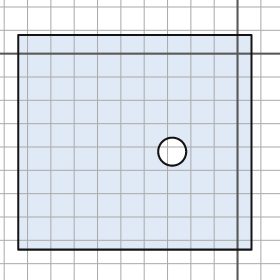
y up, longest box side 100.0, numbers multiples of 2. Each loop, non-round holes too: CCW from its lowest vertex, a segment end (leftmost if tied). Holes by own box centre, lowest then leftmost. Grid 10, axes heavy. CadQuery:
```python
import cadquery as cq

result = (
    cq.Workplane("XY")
    .moveTo(-94.0, -84.0)
    .lineTo(6.0, -84.0)
    .lineTo(6.0, 8.0)
    .lineTo(-94.0, 8.0)
    .close()
    .moveTo(-28.0, -42.0)
    .circle(6.0)
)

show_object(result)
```